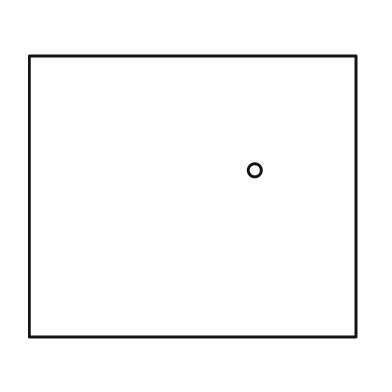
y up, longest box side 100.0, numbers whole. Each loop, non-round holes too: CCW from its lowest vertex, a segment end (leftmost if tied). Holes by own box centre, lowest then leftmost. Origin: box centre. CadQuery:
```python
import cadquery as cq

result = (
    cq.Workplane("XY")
    .moveTo(-50.0, -43.0)
    .lineTo(50.0, -43.0)
    .lineTo(50.0, 43.0)
    .lineTo(-50.0, 43.0)
    .close()
    .moveTo(19.0, 8.0)
    .circle(2.0)
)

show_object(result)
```